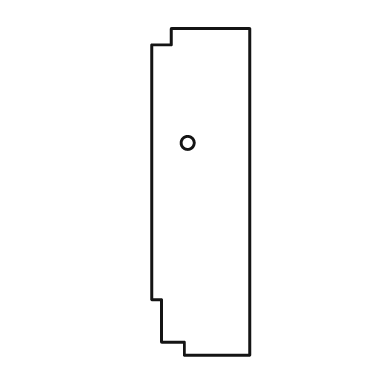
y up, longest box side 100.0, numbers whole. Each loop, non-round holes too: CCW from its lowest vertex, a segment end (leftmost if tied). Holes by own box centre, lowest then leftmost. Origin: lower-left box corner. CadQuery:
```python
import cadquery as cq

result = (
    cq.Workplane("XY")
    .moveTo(10.0, 0.0)
    .lineTo(30.0, 0.0)
    .lineTo(30.0, 100.0)
    .lineTo(6.0, 100.0)
    .lineTo(6.0, 95.0)
    .lineTo(0.0, 95.0)
    .lineTo(0.0, 17.0)
    .lineTo(3.0, 17.0)
    .lineTo(3.0, 4.0)
    .lineTo(10.0, 4.0)
    .close()
    .moveTo(11.0, 65.0)
    .circle(2.0)
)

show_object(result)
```